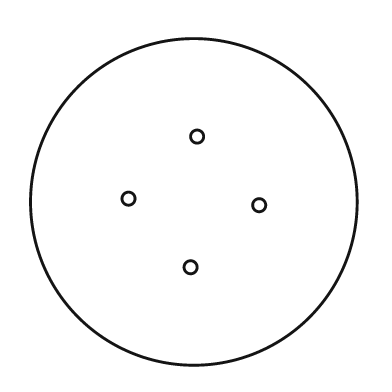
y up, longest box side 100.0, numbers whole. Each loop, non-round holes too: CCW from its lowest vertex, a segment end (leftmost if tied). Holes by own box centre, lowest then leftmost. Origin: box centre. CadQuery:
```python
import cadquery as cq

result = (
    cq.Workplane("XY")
    .moveTo(0.0, 0.0)
    .circle(50.0)
    .moveTo(-1.0, -20.0)
    .circle(2.0)
    .moveTo(20.0, -1.0)
    .circle(2.0)
    .moveTo(-20.0, 1.0)
    .circle(2.0)
    .moveTo(1.0, 20.0)
    .circle(2.0)
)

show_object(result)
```